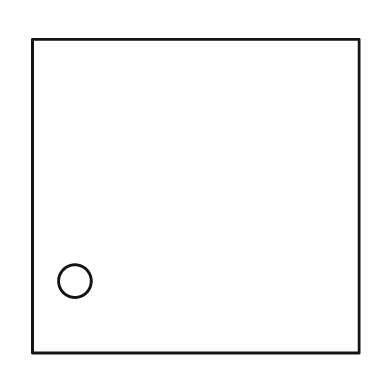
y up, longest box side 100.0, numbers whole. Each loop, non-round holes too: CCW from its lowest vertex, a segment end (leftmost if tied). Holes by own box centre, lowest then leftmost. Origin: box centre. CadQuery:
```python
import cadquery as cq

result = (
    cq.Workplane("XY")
    .moveTo(-50.0, -48.0)
    .lineTo(50.0, -48.0)
    .lineTo(50.0, 48.0)
    .lineTo(-50.0, 48.0)
    .close()
    .moveTo(-37.0, -26.0)
    .circle(5.0)
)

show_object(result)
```